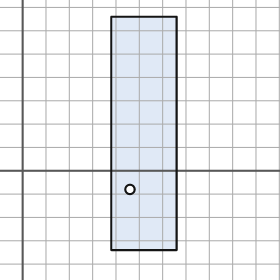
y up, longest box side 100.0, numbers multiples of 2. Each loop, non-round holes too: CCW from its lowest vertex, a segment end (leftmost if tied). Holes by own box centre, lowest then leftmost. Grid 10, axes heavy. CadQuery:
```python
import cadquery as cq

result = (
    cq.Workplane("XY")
    .moveTo(38.0, -34.0)
    .lineTo(66.0, -34.0)
    .lineTo(66.0, 66.0)
    .lineTo(38.0, 66.0)
    .close()
    .moveTo(46.0, -8.0)
    .circle(2.0)
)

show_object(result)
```